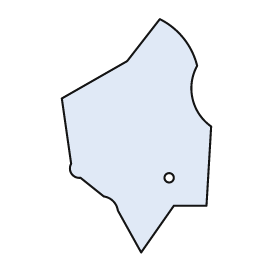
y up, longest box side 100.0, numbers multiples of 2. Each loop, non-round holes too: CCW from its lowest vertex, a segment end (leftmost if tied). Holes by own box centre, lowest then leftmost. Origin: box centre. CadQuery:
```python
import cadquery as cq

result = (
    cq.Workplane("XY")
    .moveTo(2.0, -50.0)
    .lineTo(16.0, -30.0)
    .lineTo(30.0, -30.0)
    .lineTo(32.0, 4.0)
    .threePointArc((24.0, 16.0), (26.0, 30.0))
    .threePointArc((20.0, 42.0), (10.0, 50.0))
    .lineTo(-4.0, 32.0)
    .lineTo(-32.0, 16.0)
    .lineTo(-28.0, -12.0)
    .threePointArc((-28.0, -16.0), (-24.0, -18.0))
    .lineTo(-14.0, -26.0)
    .threePointArc((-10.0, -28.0), (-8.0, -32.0))
    .close()
    .moveTo(14.0, -18.0)
    .circle(2.0)
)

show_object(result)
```